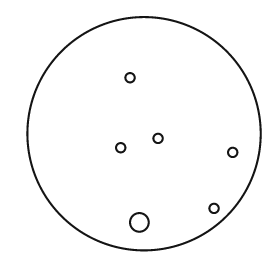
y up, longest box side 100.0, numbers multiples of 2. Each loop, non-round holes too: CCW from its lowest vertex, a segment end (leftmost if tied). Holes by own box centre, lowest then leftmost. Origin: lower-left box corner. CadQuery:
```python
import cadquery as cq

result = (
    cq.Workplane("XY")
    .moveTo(50.0, 50.0)
    .circle(50.0)
    .moveTo(48.0, 12.0)
    .circle(4.0)
    .moveTo(80.0, 18.0)
    .circle(2.0)
    .moveTo(88.0, 42.0)
    .circle(2.0)
    .moveTo(40.0, 44.0)
    .circle(2.0)
    .moveTo(56.0, 48.0)
    .circle(2.0)
    .moveTo(44.0, 74.0)
    .circle(2.0)
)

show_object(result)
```